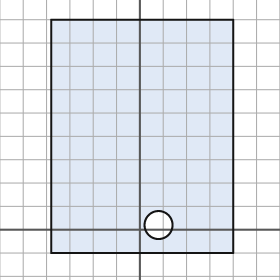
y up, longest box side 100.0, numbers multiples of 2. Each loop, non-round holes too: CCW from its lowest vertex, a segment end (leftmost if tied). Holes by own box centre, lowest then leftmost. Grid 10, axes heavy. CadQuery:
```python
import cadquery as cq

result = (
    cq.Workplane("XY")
    .moveTo(-38.0, -10.0)
    .lineTo(40.0, -10.0)
    .lineTo(40.0, 90.0)
    .lineTo(-38.0, 90.0)
    .close()
    .moveTo(8.0, 2.0)
    .circle(6.0)
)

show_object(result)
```